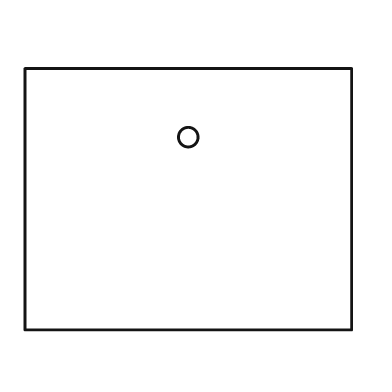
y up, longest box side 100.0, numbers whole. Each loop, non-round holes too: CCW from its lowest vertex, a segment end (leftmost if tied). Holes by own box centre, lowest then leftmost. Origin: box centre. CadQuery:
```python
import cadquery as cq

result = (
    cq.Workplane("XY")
    .moveTo(-50.0, -40.0)
    .lineTo(50.0, -40.0)
    .lineTo(50.0, 40.0)
    .lineTo(-50.0, 40.0)
    .close()
    .moveTo(0.0, 19.0)
    .circle(3.0)
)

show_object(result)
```